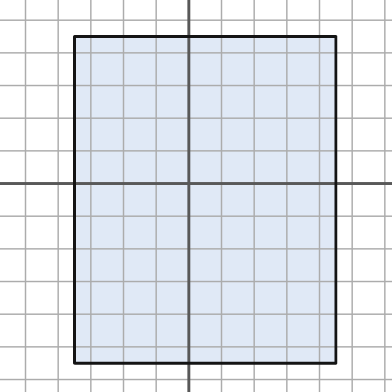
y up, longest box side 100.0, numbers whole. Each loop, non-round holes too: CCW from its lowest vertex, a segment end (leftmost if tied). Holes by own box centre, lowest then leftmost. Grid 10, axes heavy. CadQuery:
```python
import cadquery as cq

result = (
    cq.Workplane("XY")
    .moveTo(-35.0, -55.0)
    .lineTo(45.0, -55.0)
    .lineTo(45.0, 45.0)
    .lineTo(-35.0, 45.0)
    .close()
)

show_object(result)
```